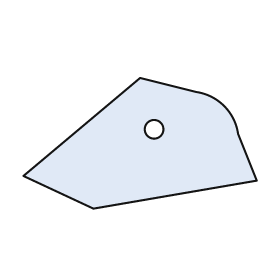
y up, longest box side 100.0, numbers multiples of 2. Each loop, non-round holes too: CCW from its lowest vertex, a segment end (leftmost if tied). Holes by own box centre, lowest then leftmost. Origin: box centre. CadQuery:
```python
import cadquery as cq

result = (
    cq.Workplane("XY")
    .moveTo(-20.0, -28.0)
    .lineTo(50.0, -16.0)
    .lineTo(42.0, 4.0)
    .threePointArc((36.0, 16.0), (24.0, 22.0))
    .lineTo(0.0, 28.0)
    .lineTo(-50.0, -14.0)
    .close()
    .moveTo(6.0, 6.0)
    .circle(4.0)
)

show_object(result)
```